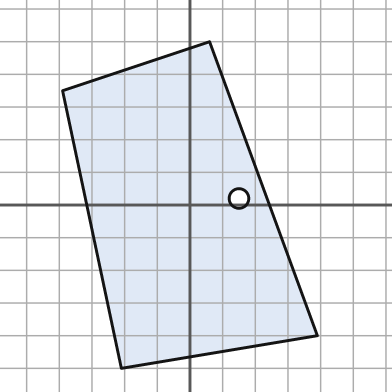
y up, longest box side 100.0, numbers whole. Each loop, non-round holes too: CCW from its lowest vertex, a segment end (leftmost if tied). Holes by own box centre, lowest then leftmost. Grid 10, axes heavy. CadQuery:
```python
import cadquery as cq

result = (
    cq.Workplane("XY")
    .moveTo(-21.0, -50.0)
    .lineTo(39.0, -40.0)
    .lineTo(6.0, 50.0)
    .lineTo(-39.0, 35.0)
    .close()
    .moveTo(15.0, 2.0)
    .circle(3.0)
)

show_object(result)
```